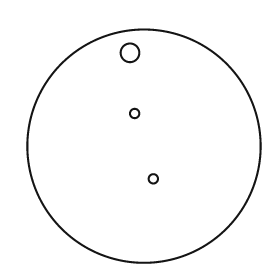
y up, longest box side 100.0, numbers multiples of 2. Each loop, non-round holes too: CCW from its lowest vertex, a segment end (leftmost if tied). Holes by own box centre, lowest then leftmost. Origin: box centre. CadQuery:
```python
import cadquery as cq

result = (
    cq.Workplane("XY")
    .moveTo(0.0, 0.0)
    .circle(50.0)
    .moveTo(4.0, -14.0)
    .circle(2.0)
    .moveTo(-4.0, 14.0)
    .circle(2.0)
    .moveTo(-6.0, 40.0)
    .circle(4.0)
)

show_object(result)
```